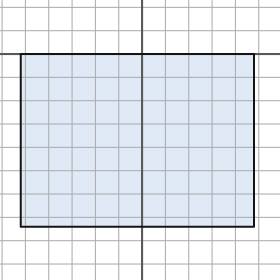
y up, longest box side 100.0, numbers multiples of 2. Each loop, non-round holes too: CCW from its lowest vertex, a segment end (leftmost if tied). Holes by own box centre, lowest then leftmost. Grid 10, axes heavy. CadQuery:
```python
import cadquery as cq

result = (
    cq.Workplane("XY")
    .moveTo(-52.0, -74.0)
    .lineTo(48.0, -74.0)
    .lineTo(48.0, 0.0)
    .lineTo(-52.0, 0.0)
    .close()
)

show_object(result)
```